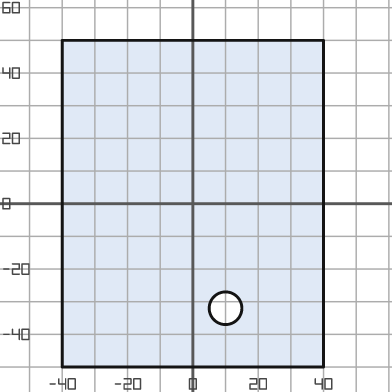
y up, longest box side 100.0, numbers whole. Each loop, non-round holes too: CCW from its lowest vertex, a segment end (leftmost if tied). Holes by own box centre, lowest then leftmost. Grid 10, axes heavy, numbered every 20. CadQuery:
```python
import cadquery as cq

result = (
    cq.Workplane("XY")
    .moveTo(-40.0, -50.0)
    .lineTo(40.0, -50.0)
    .lineTo(40.0, 50.0)
    .lineTo(-40.0, 50.0)
    .close()
    .moveTo(10.0, -32.0)
    .circle(5.0)
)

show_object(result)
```